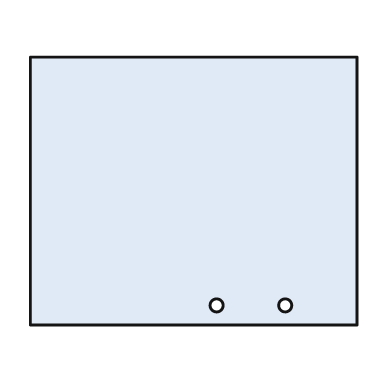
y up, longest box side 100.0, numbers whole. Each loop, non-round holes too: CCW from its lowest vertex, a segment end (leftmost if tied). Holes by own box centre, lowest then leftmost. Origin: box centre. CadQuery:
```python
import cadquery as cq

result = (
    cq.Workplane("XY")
    .moveTo(-50.0, -41.0)
    .lineTo(50.0, -41.0)
    .lineTo(50.0, 41.0)
    .lineTo(-50.0, 41.0)
    .close()
    .moveTo(7.0, -35.0)
    .circle(2.0)
    .moveTo(28.0, -35.0)
    .circle(2.0)
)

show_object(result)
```